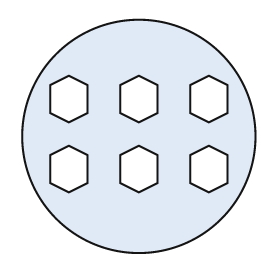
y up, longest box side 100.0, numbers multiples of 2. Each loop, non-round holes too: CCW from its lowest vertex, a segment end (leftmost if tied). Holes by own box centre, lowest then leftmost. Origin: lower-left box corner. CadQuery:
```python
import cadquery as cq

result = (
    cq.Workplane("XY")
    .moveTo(50.0, 50.0)
    .circle(50.0)
    .moveTo(20.0, 26.0)
    .lineTo(28.0, 30.0)
    .lineTo(28.0, 42.0)
    .lineTo(20.0, 46.0)
    .lineTo(12.0, 42.0)
    .lineTo(12.0, 30.0)
    .close()
    .moveTo(50.0, 26.0)
    .lineTo(58.0, 30.0)
    .lineTo(58.0, 42.0)
    .lineTo(50.0, 46.0)
    .lineTo(42.0, 42.0)
    .lineTo(42.0, 30.0)
    .close()
    .moveTo(80.0, 26.0)
    .lineTo(88.0, 30.0)
    .lineTo(88.0, 42.0)
    .lineTo(80.0, 46.0)
    .lineTo(72.0, 42.0)
    .lineTo(72.0, 30.0)
    .close()
    .moveTo(20.0, 56.0)
    .lineTo(28.0, 60.0)
    .lineTo(28.0, 72.0)
    .lineTo(20.0, 76.0)
    .lineTo(12.0, 72.0)
    .lineTo(12.0, 60.0)
    .close()
    .moveTo(50.0, 56.0)
    .lineTo(58.0, 60.0)
    .lineTo(58.0, 72.0)
    .lineTo(50.0, 76.0)
    .lineTo(42.0, 72.0)
    .lineTo(42.0, 60.0)
    .close()
    .moveTo(80.0, 56.0)
    .lineTo(88.0, 60.0)
    .lineTo(88.0, 72.0)
    .lineTo(80.0, 76.0)
    .lineTo(72.0, 72.0)
    .lineTo(72.0, 60.0)
    .close()
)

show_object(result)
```